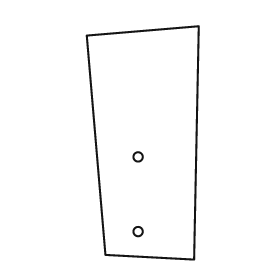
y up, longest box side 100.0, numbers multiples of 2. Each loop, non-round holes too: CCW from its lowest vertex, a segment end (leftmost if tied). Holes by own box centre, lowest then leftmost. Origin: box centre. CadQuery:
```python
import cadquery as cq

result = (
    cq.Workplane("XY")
    .moveTo(22.0, -50.0)
    .lineTo(24.0, 50.0)
    .lineTo(-24.0, 46.0)
    .lineTo(-16.0, -48.0)
    .close()
    .moveTo(-2.0, -38.0)
    .circle(2.0)
    .moveTo(-2.0, -6.0)
    .circle(2.0)
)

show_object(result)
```